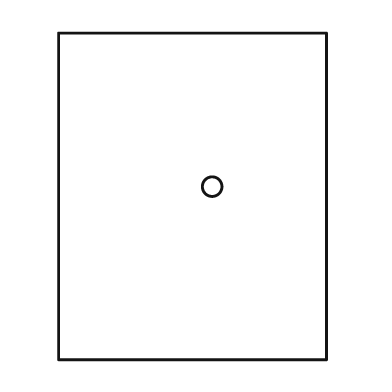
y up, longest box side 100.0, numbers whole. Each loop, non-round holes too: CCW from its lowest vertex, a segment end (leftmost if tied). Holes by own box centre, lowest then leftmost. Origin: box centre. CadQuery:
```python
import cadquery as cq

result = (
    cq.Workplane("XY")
    .moveTo(-41.0, -50.0)
    .lineTo(41.0, -50.0)
    .lineTo(41.0, 50.0)
    .lineTo(-41.0, 50.0)
    .close()
    .moveTo(6.0, 3.0)
    .circle(3.0)
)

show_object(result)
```